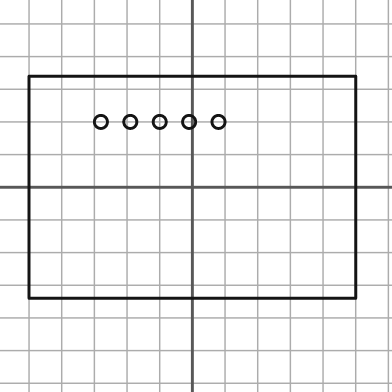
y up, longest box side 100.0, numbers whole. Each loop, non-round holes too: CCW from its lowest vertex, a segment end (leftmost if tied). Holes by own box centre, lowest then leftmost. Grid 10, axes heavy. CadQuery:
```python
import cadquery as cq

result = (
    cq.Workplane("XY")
    .moveTo(-50.0, -34.0)
    .lineTo(50.0, -34.0)
    .lineTo(50.0, 34.0)
    .lineTo(-50.0, 34.0)
    .close()
    .moveTo(-28.0, 20.0)
    .circle(2.0)
    .moveTo(-19.0, 20.0)
    .circle(2.0)
    .moveTo(-10.0, 20.0)
    .circle(2.0)
    .moveTo(-1.0, 20.0)
    .circle(2.0)
    .moveTo(8.0, 20.0)
    .circle(2.0)
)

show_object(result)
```